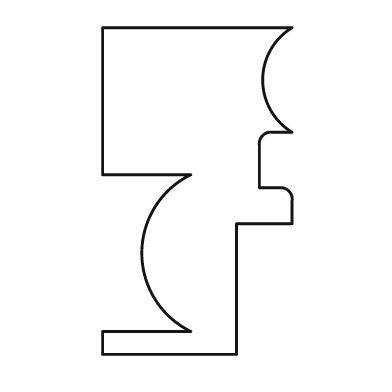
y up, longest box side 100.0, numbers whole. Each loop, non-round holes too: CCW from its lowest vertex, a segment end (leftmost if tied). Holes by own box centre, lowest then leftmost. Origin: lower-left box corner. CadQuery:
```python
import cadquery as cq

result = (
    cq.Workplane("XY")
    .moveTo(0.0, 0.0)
    .lineTo(41.0, 0.0)
    .lineTo(41.0, 40.0)
    .lineTo(58.0, 40.0)
    .lineTo(58.0, 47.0)
    .threePointArc((57.0, 50.0), (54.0, 51.0))
    .lineTo(48.0, 51.0)
    .lineTo(48.0, 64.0)
    .threePointArc((49.0, 67.0), (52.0, 68.0))
    .lineTo(58.0, 68.0)
    .threePointArc((49.0, 84.0), (58.0, 100.0))
    .lineTo(0.0, 100.0)
    .lineTo(0.0, 55.0)
    .lineTo(27.0, 55.0)
    .threePointArc((12.0, 31.0), (27.0, 7.0))
    .lineTo(0.0, 7.0)
    .close()
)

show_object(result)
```